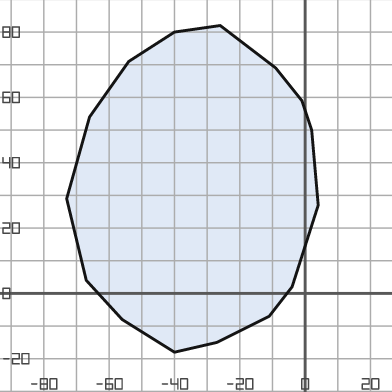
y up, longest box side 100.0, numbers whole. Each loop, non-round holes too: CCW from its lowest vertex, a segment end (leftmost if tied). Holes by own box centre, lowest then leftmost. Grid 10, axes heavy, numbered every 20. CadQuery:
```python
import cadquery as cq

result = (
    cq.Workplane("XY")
    .moveTo(-40.0, -18.0)
    .lineTo(-27.0, -15.0)
    .lineTo(-11.0, -7.0)
    .lineTo(-4.0, 2.0)
    .lineTo(4.0, 27.0)
    .lineTo(2.0, 50.0)
    .lineTo(-1.0, 59.0)
    .lineTo(-9.0, 69.0)
    .lineTo(-26.0, 82.0)
    .lineTo(-40.0, 80.0)
    .lineTo(-54.0, 71.0)
    .lineTo(-66.0, 54.0)
    .lineTo(-73.0, 29.0)
    .lineTo(-67.0, 4.0)
    .lineTo(-56.0, -8.0)
    .close()
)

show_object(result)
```